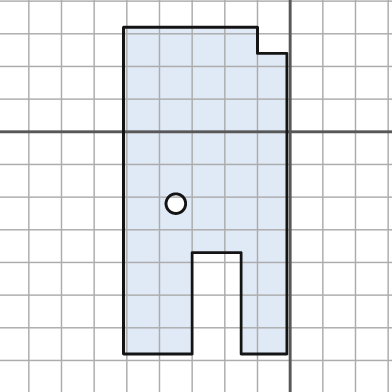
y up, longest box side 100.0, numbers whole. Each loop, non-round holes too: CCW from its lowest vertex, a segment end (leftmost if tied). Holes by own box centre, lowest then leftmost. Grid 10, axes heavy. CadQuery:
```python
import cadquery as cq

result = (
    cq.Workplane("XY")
    .moveTo(-51.0, -68.0)
    .lineTo(-30.0, -68.0)
    .lineTo(-30.0, -37.0)
    .lineTo(-15.0, -37.0)
    .lineTo(-15.0, -68.0)
    .lineTo(-1.0, -68.0)
    .lineTo(-1.0, 24.0)
    .lineTo(-10.0, 24.0)
    .lineTo(-10.0, 32.0)
    .lineTo(-51.0, 32.0)
    .close()
    .moveTo(-35.0, -22.0)
    .circle(3.0)
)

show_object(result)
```